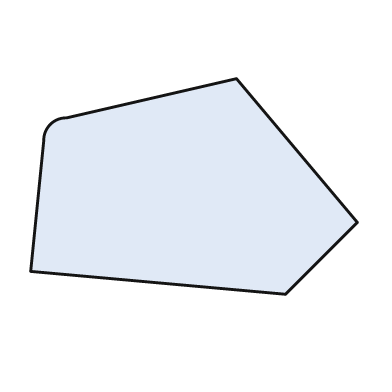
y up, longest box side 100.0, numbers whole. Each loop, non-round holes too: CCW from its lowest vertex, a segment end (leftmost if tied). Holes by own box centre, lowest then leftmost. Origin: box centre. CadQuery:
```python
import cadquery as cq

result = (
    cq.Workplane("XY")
    .moveTo(28.0, -33.0)
    .lineTo(50.0, -11.0)
    .lineTo(13.0, 33.0)
    .lineTo(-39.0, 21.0)
    .threePointArc((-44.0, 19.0), (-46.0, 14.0))
    .lineTo(-50.0, -26.0)
    .close()
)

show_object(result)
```